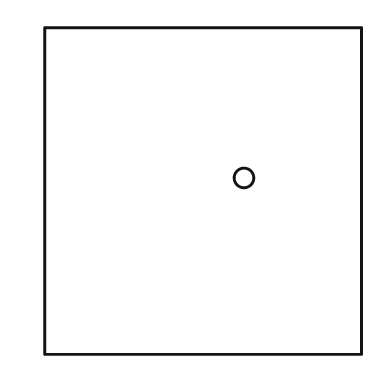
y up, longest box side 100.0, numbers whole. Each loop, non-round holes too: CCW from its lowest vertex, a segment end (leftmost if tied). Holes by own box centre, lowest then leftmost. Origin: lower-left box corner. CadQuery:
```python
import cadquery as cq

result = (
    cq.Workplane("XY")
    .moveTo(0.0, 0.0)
    .lineTo(97.0, 0.0)
    .lineTo(97.0, 100.0)
    .lineTo(0.0, 100.0)
    .close()
    .moveTo(61.0, 54.0)
    .circle(3.0)
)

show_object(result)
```